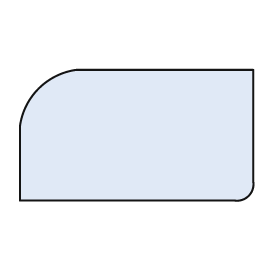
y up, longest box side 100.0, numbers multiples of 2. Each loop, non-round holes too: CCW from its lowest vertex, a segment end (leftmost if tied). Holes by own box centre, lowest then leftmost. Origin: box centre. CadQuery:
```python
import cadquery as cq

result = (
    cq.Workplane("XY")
    .moveTo(-50.0, -28.0)
    .lineTo(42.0, -28.0)
    .threePointArc((48.0, -26.0), (50.0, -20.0))
    .lineTo(50.0, 28.0)
    .lineTo(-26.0, 28.0)
    .threePointArc((-42.0, 20.0), (-50.0, 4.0))
    .close()
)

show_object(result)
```